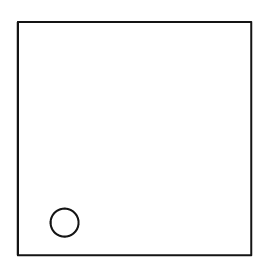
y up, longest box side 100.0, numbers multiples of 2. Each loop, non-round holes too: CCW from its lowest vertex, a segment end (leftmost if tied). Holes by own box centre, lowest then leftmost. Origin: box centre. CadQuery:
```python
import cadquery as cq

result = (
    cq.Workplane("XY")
    .moveTo(-50.0, -50.0)
    .lineTo(50.0, -50.0)
    .lineTo(50.0, 50.0)
    .lineTo(-50.0, 50.0)
    .close()
    .moveTo(-30.0, -36.0)
    .circle(6.0)
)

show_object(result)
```